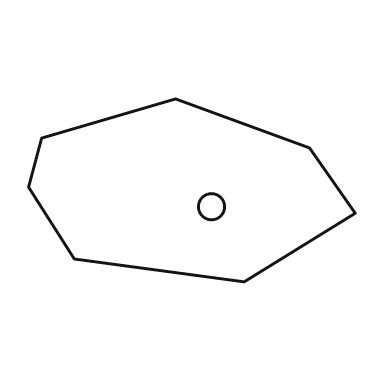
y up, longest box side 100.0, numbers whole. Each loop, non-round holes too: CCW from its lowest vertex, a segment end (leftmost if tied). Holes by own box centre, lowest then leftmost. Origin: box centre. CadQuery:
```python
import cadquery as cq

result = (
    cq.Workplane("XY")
    .moveTo(16.0, -28.0)
    .lineTo(50.0, -7.0)
    .lineTo(36.0, 13.0)
    .lineTo(-5.0, 28.0)
    .lineTo(-46.0, 16.0)
    .lineTo(-50.0, 1.0)
    .lineTo(-36.0, -21.0)
    .close()
    .moveTo(6.0, -5.0)
    .circle(4.0)
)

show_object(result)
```